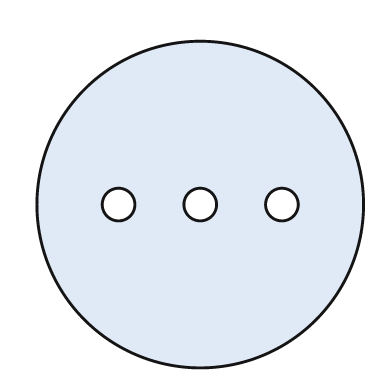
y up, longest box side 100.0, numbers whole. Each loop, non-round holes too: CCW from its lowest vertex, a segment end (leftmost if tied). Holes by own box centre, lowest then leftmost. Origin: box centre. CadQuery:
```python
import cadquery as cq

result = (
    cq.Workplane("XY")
    .moveTo(0.0, 0.0)
    .circle(50.0)
    .moveTo(-25.0, 0.0)
    .circle(5.0)
    .moveTo(0.0, 0.0)
    .circle(5.0)
    .moveTo(25.0, 0.0)
    .circle(5.0)
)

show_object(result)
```